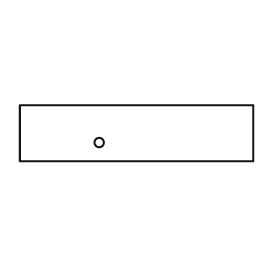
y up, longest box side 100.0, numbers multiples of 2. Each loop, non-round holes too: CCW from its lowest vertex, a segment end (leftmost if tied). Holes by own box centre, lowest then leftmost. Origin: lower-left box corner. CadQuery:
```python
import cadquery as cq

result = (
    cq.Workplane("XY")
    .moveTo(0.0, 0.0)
    .lineTo(100.0, 0.0)
    .lineTo(100.0, 24.0)
    .lineTo(0.0, 24.0)
    .close()
    .moveTo(34.0, 8.0)
    .circle(2.0)
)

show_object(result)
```